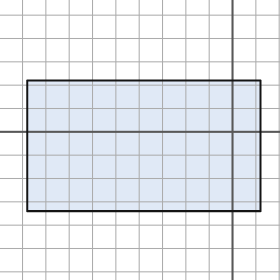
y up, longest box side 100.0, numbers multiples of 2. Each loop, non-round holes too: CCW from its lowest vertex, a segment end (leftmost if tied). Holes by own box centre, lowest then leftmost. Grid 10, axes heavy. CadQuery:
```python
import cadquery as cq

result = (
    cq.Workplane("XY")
    .moveTo(-88.0, -34.0)
    .lineTo(12.0, -34.0)
    .lineTo(12.0, 22.0)
    .lineTo(-88.0, 22.0)
    .close()
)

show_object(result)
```